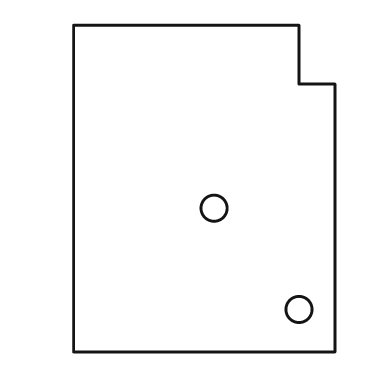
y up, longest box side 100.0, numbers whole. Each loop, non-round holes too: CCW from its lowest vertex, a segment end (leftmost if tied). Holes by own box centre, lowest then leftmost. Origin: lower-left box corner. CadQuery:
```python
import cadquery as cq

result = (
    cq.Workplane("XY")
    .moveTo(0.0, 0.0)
    .lineTo(80.0, 0.0)
    .lineTo(80.0, 82.0)
    .lineTo(69.0, 82.0)
    .lineTo(69.0, 100.0)
    .lineTo(0.0, 100.0)
    .close()
    .moveTo(69.0, 13.0)
    .circle(4.0)
    .moveTo(43.0, 44.0)
    .circle(4.0)
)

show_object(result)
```